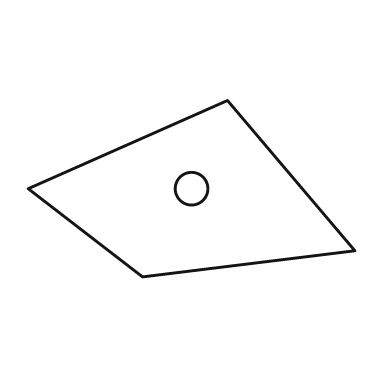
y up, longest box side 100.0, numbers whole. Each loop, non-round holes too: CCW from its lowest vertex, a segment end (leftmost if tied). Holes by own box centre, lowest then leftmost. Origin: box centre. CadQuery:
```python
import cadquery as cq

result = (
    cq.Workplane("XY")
    .moveTo(-15.0, -27.0)
    .lineTo(50.0, -19.0)
    .lineTo(11.0, 27.0)
    .lineTo(-50.0, 0.0)
    .close()
    .moveTo(0.0, 0.0)
    .circle(5.0)
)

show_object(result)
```